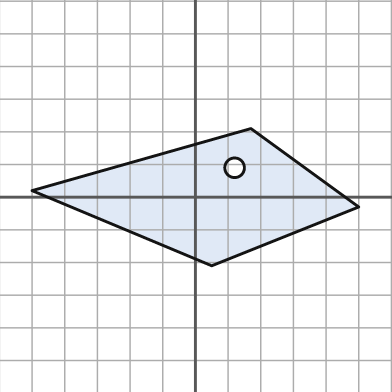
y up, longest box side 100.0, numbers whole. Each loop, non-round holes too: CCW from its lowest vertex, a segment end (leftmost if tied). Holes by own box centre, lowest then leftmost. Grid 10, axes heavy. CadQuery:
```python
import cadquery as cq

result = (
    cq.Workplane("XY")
    .moveTo(5.0, -21.0)
    .lineTo(50.0, -3.0)
    .lineTo(17.0, 21.0)
    .lineTo(-50.0, 2.0)
    .close()
    .moveTo(12.0, 9.0)
    .circle(3.0)
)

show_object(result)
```